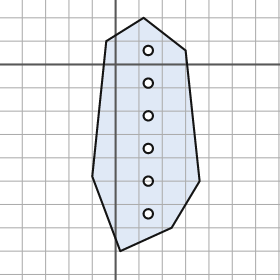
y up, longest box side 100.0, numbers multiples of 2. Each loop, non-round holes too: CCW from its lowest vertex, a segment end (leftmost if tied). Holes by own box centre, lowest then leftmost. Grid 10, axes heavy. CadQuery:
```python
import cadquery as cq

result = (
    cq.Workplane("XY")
    .moveTo(2.0, -80.0)
    .lineTo(24.0, -70.0)
    .lineTo(36.0, -50.0)
    .lineTo(30.0, 6.0)
    .lineTo(12.0, 20.0)
    .lineTo(-4.0, 10.0)
    .lineTo(-10.0, -48.0)
    .close()
    .moveTo(14.0, -64.0)
    .circle(2.0)
    .moveTo(14.0, -50.0)
    .circle(2.0)
    .moveTo(14.0, -36.0)
    .circle(2.0)
    .moveTo(14.0, -22.0)
    .circle(2.0)
    .moveTo(14.0, -8.0)
    .circle(2.0)
    .moveTo(14.0, 6.0)
    .circle(2.0)
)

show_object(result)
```